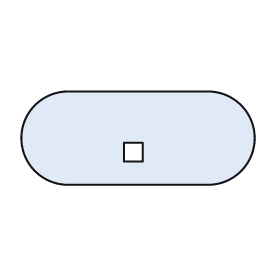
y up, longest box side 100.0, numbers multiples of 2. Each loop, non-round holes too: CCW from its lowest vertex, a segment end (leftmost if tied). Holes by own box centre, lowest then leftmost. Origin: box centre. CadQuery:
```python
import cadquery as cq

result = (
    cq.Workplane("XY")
    .moveTo(-30.0, -20.0)
    .lineTo(30.0, -20.0)
    .threePointArc((50.0, 0.0), (30.0, 20.0))
    .lineTo(-30.0, 20.0)
    .threePointArc((-50.0, 0.0), (-30.0, -20.0))
    .close()
    .moveTo(-6.0, -10.0)
    .lineTo(2.0, -10.0)
    .lineTo(2.0, -2.0)
    .lineTo(-6.0, -2.0)
    .close()
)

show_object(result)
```